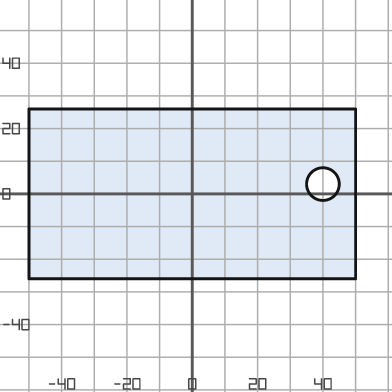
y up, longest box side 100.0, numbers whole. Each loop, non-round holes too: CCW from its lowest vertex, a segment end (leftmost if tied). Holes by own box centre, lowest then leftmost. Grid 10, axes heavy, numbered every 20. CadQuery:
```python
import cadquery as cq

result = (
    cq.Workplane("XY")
    .moveTo(-50.0, -26.0)
    .lineTo(50.0, -26.0)
    .lineTo(50.0, 26.0)
    .lineTo(-50.0, 26.0)
    .close()
    .moveTo(40.0, 3.0)
    .circle(5.0)
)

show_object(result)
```